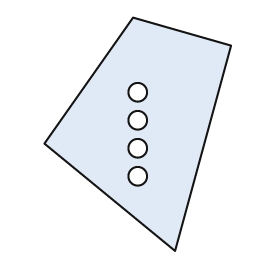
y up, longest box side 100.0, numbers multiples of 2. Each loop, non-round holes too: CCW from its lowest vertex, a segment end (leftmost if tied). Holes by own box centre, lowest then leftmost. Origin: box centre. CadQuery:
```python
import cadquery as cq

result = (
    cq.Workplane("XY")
    .moveTo(16.0, -50.0)
    .lineTo(40.0, 38.0)
    .lineTo(-2.0, 50.0)
    .lineTo(-40.0, -4.0)
    .close()
    .moveTo(0.0, -18.0)
    .circle(4.0)
    .moveTo(0.0, -6.0)
    .circle(4.0)
    .moveTo(0.0, 6.0)
    .circle(4.0)
    .moveTo(0.0, 18.0)
    .circle(4.0)
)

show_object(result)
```